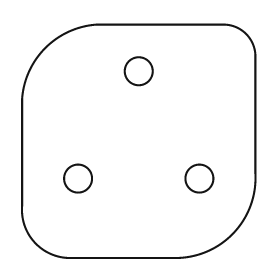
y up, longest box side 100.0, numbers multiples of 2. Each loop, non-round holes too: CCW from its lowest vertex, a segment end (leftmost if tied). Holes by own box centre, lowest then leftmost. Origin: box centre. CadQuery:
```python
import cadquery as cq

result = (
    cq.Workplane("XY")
    .moveTo(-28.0, -50.0)
    .lineTo(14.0, -50.0)
    .threePointArc((40.0, -40.0), (50.0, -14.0))
    .lineTo(50.0, 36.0)
    .threePointArc((46.0, 46.0), (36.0, 50.0))
    .lineTo(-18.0, 50.0)
    .threePointArc((-40.0, 40.0), (-50.0, 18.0))
    .lineTo(-50.0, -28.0)
    .threePointArc((-44.0, -44.0), (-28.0, -50.0))
    .close()
    .moveTo(-26.0, -16.0)
    .circle(6.0)
    .moveTo(26.0, -16.0)
    .circle(6.0)
    .moveTo(0.0, 30.0)
    .circle(6.0)
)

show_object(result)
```